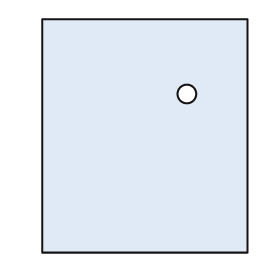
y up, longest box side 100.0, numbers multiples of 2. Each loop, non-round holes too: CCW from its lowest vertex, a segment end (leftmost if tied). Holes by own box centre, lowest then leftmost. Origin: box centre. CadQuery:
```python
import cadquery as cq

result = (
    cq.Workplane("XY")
    .moveTo(-44.0, -50.0)
    .lineTo(44.0, -50.0)
    .lineTo(44.0, 50.0)
    .lineTo(-44.0, 50.0)
    .close()
    .moveTo(18.0, 18.0)
    .circle(4.0)
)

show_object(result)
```